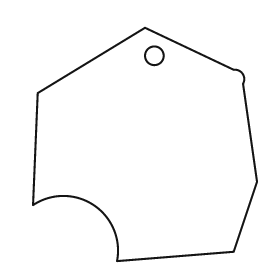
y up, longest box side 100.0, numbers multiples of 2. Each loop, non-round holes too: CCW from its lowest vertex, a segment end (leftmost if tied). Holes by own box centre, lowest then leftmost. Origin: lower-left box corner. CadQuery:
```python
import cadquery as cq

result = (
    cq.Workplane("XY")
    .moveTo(36.0, 0.0)
    .lineTo(86.0, 4.0)
    .lineTo(96.0, 34.0)
    .lineTo(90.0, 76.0)
    .threePointArc((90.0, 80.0), (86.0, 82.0))
    .lineTo(48.0, 100.0)
    .lineTo(2.0, 72.0)
    .lineTo(0.0, 24.0)
    .threePointArc((26.0, 24.0), (36.0, 0.0))
    .close()
    .moveTo(52.0, 88.0)
    .circle(4.0)
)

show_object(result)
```